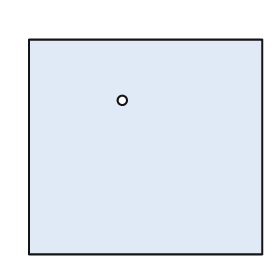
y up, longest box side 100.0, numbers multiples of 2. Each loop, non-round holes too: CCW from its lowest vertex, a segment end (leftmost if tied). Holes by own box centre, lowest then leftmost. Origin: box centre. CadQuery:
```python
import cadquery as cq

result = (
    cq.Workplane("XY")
    .moveTo(-50.0, -46.0)
    .lineTo(50.0, -46.0)
    .lineTo(50.0, 46.0)
    .lineTo(-50.0, 46.0)
    .close()
    .moveTo(-10.0, 20.0)
    .circle(2.0)
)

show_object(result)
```